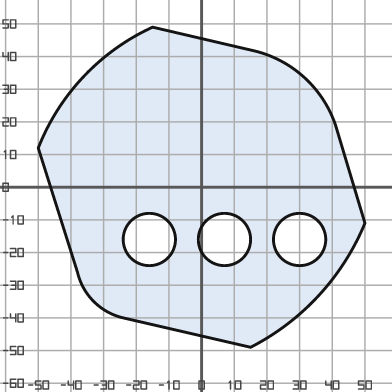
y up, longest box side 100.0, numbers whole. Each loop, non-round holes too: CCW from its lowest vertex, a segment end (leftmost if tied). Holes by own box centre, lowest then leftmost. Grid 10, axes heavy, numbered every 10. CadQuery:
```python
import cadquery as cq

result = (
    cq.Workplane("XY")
    .moveTo(15.0, -49.0)
    .threePointArc((36.0, -33.0), (50.0, -11.0))
    .lineTo(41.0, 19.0)
    .threePointArc((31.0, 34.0), (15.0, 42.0))
    .lineTo(-15.0, 49.0)
    .threePointArc((-36.0, 34.0), (-50.0, 12.0))
    .lineTo(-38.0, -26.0)
    .threePointArc((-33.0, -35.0), (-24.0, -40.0))
    .close()
    .moveTo(-16.0, -16.0)
    .circle(8.0)
    .moveTo(7.0, -16.0)
    .circle(8.0)
    .moveTo(30.0, -16.0)
    .circle(8.0)
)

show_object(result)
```